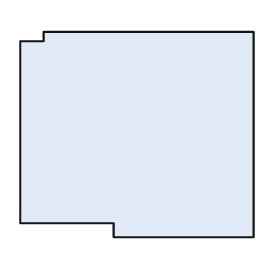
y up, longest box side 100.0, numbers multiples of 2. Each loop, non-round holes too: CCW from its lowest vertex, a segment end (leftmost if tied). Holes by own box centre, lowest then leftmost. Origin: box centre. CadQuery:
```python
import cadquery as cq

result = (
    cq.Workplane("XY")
    .moveTo(-10.0, -44.0)
    .lineTo(50.0, -44.0)
    .lineTo(50.0, 44.0)
    .lineTo(-40.0, 44.0)
    .lineTo(-40.0, 40.0)
    .lineTo(-50.0, 40.0)
    .lineTo(-50.0, -38.0)
    .lineTo(-10.0, -38.0)
    .close()
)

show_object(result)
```